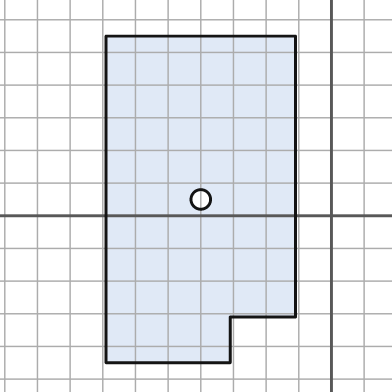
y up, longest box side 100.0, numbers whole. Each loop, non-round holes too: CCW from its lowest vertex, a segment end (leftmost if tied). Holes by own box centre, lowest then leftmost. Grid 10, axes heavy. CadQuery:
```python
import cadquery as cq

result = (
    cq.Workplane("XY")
    .moveTo(-69.0, -45.0)
    .lineTo(-31.0, -45.0)
    .lineTo(-31.0, -31.0)
    .lineTo(-11.0, -31.0)
    .lineTo(-11.0, 55.0)
    .lineTo(-69.0, 55.0)
    .close()
    .moveTo(-40.0, 5.0)
    .circle(3.0)
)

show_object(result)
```